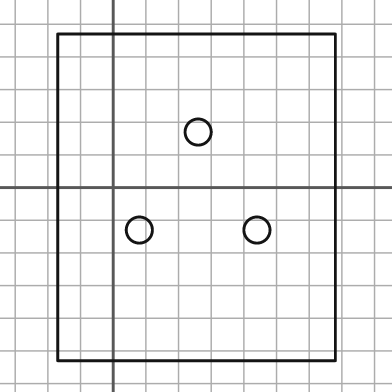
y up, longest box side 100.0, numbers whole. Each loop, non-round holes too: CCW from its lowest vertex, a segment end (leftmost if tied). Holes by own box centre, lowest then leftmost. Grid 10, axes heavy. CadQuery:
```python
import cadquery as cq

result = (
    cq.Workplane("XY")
    .moveTo(-17.0, -53.0)
    .lineTo(68.0, -53.0)
    .lineTo(68.0, 47.0)
    .lineTo(-17.0, 47.0)
    .close()
    .moveTo(8.0, -13.0)
    .circle(4.0)
    .moveTo(44.0, -13.0)
    .circle(4.0)
    .moveTo(26.0, 17.0)
    .circle(4.0)
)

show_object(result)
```